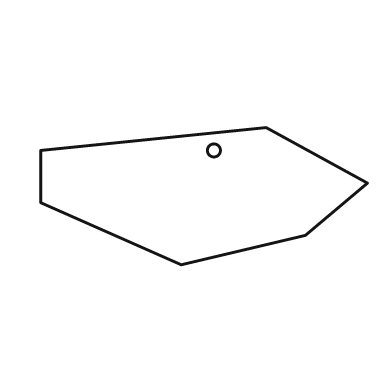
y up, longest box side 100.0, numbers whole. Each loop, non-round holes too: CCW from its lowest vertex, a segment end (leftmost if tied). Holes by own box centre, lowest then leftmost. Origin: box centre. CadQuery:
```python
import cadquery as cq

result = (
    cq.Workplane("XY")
    .moveTo(-7.0, -21.0)
    .lineTo(31.0, -12.0)
    .lineTo(50.0, 4.0)
    .lineTo(19.0, 21.0)
    .lineTo(-50.0, 14.0)
    .lineTo(-50.0, -2.0)
    .close()
    .moveTo(3.0, 14.0)
    .circle(2.0)
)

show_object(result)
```